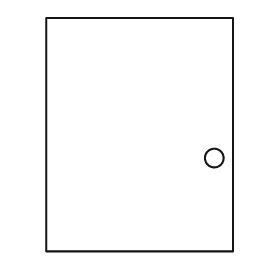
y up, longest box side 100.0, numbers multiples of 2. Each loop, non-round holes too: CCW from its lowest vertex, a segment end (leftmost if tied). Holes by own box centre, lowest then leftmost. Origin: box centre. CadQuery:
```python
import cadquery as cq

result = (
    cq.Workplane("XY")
    .moveTo(-40.0, -50.0)
    .lineTo(40.0, -50.0)
    .lineTo(40.0, 50.0)
    .lineTo(-40.0, 50.0)
    .close()
    .moveTo(32.0, -10.0)
    .circle(4.0)
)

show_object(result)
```